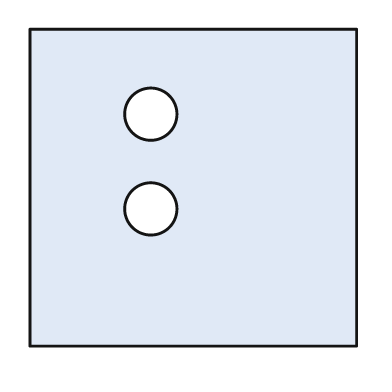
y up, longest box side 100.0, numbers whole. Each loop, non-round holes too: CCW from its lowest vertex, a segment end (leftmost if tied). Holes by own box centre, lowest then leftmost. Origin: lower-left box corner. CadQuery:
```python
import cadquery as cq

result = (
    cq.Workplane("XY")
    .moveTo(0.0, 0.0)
    .lineTo(100.0, 0.0)
    .lineTo(100.0, 97.0)
    .lineTo(0.0, 97.0)
    .close()
    .moveTo(37.0, 42.0)
    .circle(8.0)
    .moveTo(37.0, 71.0)
    .circle(8.0)
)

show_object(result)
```